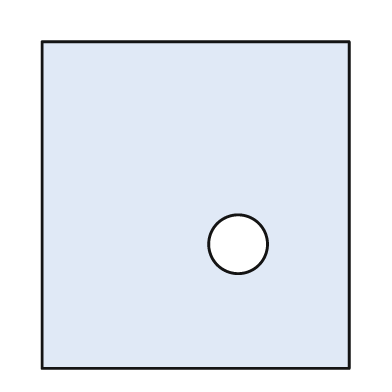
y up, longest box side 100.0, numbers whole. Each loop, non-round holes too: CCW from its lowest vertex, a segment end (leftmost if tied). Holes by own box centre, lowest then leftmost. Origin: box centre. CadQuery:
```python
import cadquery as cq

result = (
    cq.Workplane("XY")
    .moveTo(-47.0, -50.0)
    .lineTo(47.0, -50.0)
    .lineTo(47.0, 50.0)
    .lineTo(-47.0, 50.0)
    .close()
    .moveTo(13.0, -12.0)
    .circle(9.0)
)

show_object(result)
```